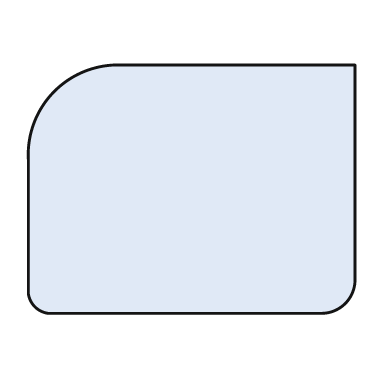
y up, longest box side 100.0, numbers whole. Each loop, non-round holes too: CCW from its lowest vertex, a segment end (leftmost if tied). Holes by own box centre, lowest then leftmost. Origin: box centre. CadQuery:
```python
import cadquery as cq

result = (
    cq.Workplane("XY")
    .moveTo(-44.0, -38.0)
    .lineTo(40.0, -38.0)
    .threePointArc((47.0, -35.0), (50.0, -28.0))
    .lineTo(50.0, 38.0)
    .lineTo(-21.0, 38.0)
    .threePointArc((-42.0, 30.0), (-50.0, 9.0))
    .lineTo(-50.0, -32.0)
    .threePointArc((-48.0, -36.0), (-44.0, -38.0))
    .close()
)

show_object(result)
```